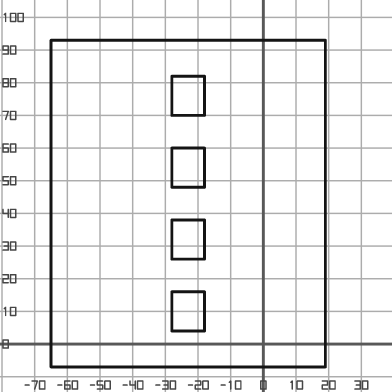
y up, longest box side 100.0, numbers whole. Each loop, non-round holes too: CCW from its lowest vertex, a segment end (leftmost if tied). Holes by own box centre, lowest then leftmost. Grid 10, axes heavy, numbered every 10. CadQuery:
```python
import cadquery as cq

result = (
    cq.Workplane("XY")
    .moveTo(-65.0, -7.0)
    .lineTo(19.0, -7.0)
    .lineTo(19.0, 93.0)
    .lineTo(-65.0, 93.0)
    .close()
    .moveTo(-28.0, 4.0)
    .lineTo(-18.0, 4.0)
    .lineTo(-18.0, 16.0)
    .lineTo(-28.0, 16.0)
    .close()
    .moveTo(-28.0, 26.0)
    .lineTo(-18.0, 26.0)
    .lineTo(-18.0, 38.0)
    .lineTo(-28.0, 38.0)
    .close()
    .moveTo(-28.0, 48.0)
    .lineTo(-18.0, 48.0)
    .lineTo(-18.0, 60.0)
    .lineTo(-28.0, 60.0)
    .close()
    .moveTo(-28.0, 70.0)
    .lineTo(-18.0, 70.0)
    .lineTo(-18.0, 82.0)
    .lineTo(-28.0, 82.0)
    .close()
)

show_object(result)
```